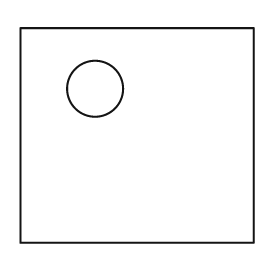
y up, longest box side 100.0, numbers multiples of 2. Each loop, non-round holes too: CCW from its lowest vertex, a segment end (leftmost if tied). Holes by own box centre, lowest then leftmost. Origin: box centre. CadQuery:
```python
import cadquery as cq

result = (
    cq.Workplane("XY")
    .moveTo(-50.0, -46.0)
    .lineTo(50.0, -46.0)
    .lineTo(50.0, 46.0)
    .lineTo(-50.0, 46.0)
    .close()
    .moveTo(-18.0, 20.0)
    .circle(12.0)
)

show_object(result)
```